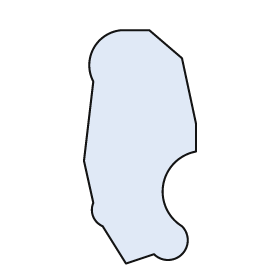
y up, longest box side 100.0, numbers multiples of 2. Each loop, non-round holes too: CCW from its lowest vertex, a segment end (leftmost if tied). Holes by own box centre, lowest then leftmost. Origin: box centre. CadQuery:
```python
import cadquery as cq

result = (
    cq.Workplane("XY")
    .moveTo(-6.0, -50.0)
    .lineTo(6.0, -46.0)
    .threePointArc((18.0, -46.0), (18.0, -34.0))
    .threePointArc((10.0, -16.0), (24.0, -2.0))
    .lineTo(24.0, 10.0)
    .lineTo(18.0, 38.0)
    .lineTo(4.0, 50.0)
    .lineTo(-8.0, 50.0)
    .threePointArc((-20.0, 42.0), (-20.0, 28.0))
    .lineTo(-24.0, -6.0)
    .lineTo(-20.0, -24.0)
    .threePointArc((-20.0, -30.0), (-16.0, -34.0))
    .close()
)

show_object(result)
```